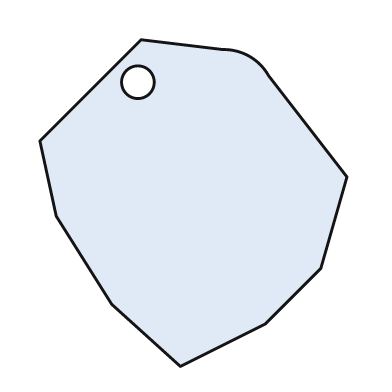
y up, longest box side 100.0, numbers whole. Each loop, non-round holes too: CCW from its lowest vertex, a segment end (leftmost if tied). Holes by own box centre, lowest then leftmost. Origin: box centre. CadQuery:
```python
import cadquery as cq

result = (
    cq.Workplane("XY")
    .moveTo(-4.0, -50.0)
    .lineTo(22.0, -37.0)
    .lineTo(39.0, -20.0)
    .lineTo(47.0, 8.0)
    .lineTo(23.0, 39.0)
    .threePointArc((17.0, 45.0), (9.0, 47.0))
    .lineTo(-16.0, 50.0)
    .lineTo(-47.0, 19.0)
    .lineTo(-42.0, -4.0)
    .lineTo(-25.0, -31.0)
    .close()
    .moveTo(-17.0, 37.0)
    .circle(5.0)
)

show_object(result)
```